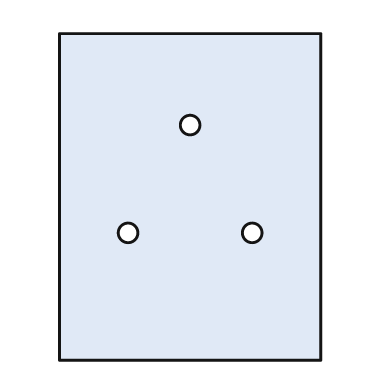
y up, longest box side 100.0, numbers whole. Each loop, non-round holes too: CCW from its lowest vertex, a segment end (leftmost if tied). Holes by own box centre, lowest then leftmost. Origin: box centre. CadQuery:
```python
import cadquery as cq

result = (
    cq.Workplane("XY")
    .moveTo(-40.0, -50.0)
    .lineTo(40.0, -50.0)
    .lineTo(40.0, 50.0)
    .lineTo(-40.0, 50.0)
    .close()
    .moveTo(-19.0, -11.0)
    .circle(3.0)
    .moveTo(19.0, -11.0)
    .circle(3.0)
    .moveTo(0.0, 22.0)
    .circle(3.0)
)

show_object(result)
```